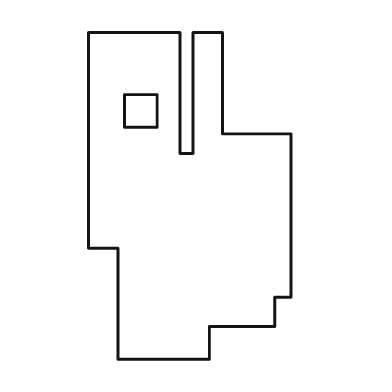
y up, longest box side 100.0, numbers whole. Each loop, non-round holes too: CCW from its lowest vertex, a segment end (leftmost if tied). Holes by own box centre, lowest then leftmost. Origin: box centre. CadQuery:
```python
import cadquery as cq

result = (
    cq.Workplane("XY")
    .moveTo(-22.0, -50.0)
    .lineTo(6.0, -50.0)
    .lineTo(6.0, -40.0)
    .lineTo(26.0, -40.0)
    .lineTo(26.0, -31.0)
    .lineTo(31.0, -31.0)
    .lineTo(31.0, 19.0)
    .lineTo(10.0, 19.0)
    .lineTo(10.0, 50.0)
    .lineTo(1.0, 50.0)
    .lineTo(1.0, 13.0)
    .lineTo(-3.0, 13.0)
    .lineTo(-3.0, 50.0)
    .lineTo(-31.0, 50.0)
    .lineTo(-31.0, -16.0)
    .lineTo(-22.0, -16.0)
    .close()
    .moveTo(-20.0, 21.0)
    .lineTo(-10.0, 21.0)
    .lineTo(-10.0, 31.0)
    .lineTo(-20.0, 31.0)
    .close()
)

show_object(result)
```